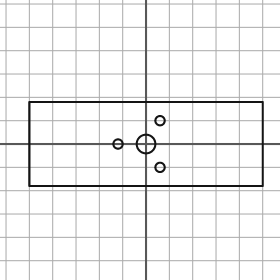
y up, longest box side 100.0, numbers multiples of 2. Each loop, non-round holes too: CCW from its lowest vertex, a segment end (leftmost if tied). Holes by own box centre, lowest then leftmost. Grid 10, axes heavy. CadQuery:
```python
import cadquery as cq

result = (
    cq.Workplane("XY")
    .moveTo(-50.0, -18.0)
    .lineTo(50.0, -18.0)
    .lineTo(50.0, 18.0)
    .lineTo(-50.0, 18.0)
    .close()
    .moveTo(6.0, -10.0)
    .circle(2.0)
    .moveTo(-12.0, 0.0)
    .circle(2.0)
    .moveTo(0.0, 0.0)
    .circle(4.0)
    .moveTo(6.0, 10.0)
    .circle(2.0)
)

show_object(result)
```